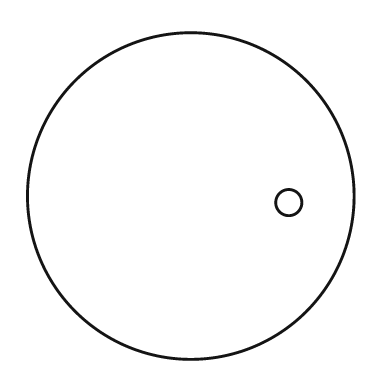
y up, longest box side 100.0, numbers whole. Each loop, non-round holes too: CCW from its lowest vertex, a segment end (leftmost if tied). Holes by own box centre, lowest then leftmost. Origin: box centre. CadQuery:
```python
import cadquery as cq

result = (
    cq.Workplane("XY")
    .moveTo(0.0, 0.0)
    .circle(50.0)
    .moveTo(30.0, -2.0)
    .circle(4.0)
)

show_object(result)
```